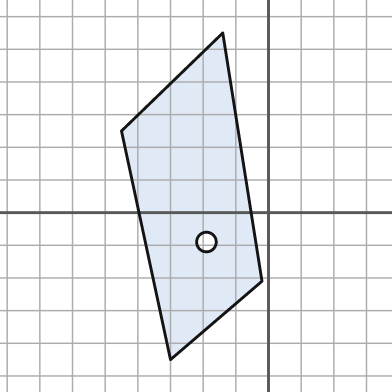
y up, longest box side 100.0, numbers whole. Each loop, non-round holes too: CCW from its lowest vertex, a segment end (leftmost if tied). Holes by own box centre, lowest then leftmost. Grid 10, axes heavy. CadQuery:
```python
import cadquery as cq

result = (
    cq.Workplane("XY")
    .moveTo(-30.0, -45.0)
    .lineTo(-2.0, -21.0)
    .lineTo(-14.0, 55.0)
    .lineTo(-45.0, 25.0)
    .close()
    .moveTo(-19.0, -9.0)
    .circle(3.0)
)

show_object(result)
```